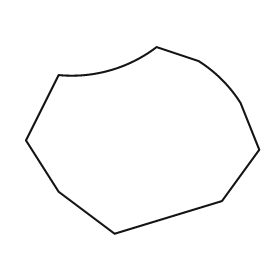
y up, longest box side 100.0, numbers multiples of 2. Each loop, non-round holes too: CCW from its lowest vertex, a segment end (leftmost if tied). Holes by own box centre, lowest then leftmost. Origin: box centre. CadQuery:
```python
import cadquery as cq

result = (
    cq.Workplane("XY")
    .moveTo(-12.0, -40.0)
    .lineTo(34.0, -26.0)
    .lineTo(50.0, -4.0)
    .lineTo(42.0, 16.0)
    .threePointArc((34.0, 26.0), (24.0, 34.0))
    .lineTo(6.0, 40.0)
    .threePointArc((-14.0, 30.0), (-36.0, 28.0))
    .lineTo(-50.0, 0.0)
    .lineTo(-36.0, -22.0)
    .close()
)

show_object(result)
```